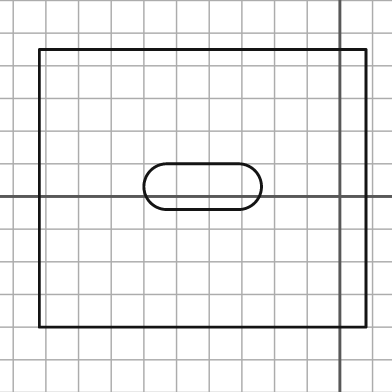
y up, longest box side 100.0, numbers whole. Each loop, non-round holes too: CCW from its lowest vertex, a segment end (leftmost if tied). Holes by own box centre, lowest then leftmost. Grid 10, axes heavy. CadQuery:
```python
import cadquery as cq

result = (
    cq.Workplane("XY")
    .moveTo(-92.0, -40.0)
    .lineTo(8.0, -40.0)
    .lineTo(8.0, 45.0)
    .lineTo(-92.0, 45.0)
    .close()
    .moveTo(-53.0, -4.0)
    .lineTo(-31.0, -4.0)
    .threePointArc((-24.0, 3.0), (-31.0, 10.0))
    .lineTo(-53.0, 10.0)
    .threePointArc((-60.0, 3.0), (-53.0, -4.0))
    .close()
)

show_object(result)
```